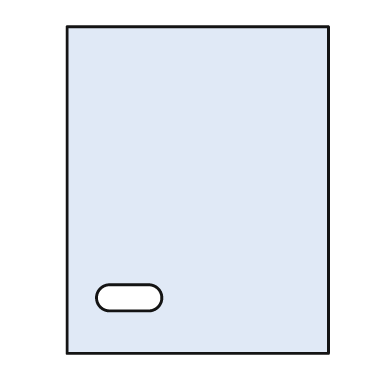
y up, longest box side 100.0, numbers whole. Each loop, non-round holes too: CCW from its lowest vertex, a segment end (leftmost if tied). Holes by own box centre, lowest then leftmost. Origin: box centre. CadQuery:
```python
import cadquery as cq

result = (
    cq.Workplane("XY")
    .moveTo(-40.0, -50.0)
    .lineTo(40.0, -50.0)
    .lineTo(40.0, 50.0)
    .lineTo(-40.0, 50.0)
    .close()
    .moveTo(-27.0, -37.0)
    .lineTo(-15.0, -37.0)
    .threePointArc((-11.0, -33.0), (-15.0, -29.0))
    .lineTo(-27.0, -29.0)
    .threePointArc((-31.0, -33.0), (-27.0, -37.0))
    .close()
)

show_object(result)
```